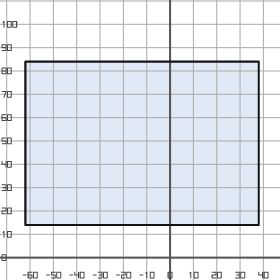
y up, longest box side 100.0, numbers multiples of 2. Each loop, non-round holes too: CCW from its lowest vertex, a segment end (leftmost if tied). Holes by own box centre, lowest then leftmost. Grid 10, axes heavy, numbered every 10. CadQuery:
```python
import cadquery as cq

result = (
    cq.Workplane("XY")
    .moveTo(-62.0, 14.0)
    .lineTo(38.0, 14.0)
    .lineTo(38.0, 84.0)
    .lineTo(-62.0, 84.0)
    .close()
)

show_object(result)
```